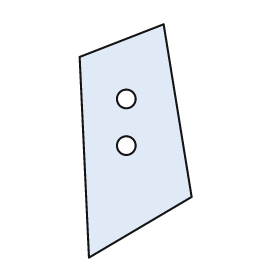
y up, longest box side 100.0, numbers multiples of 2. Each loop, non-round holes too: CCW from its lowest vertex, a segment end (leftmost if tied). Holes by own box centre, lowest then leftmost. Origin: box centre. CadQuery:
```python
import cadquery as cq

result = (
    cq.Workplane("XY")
    .moveTo(-20.0, -50.0)
    .lineTo(24.0, -24.0)
    .lineTo(12.0, 50.0)
    .lineTo(-24.0, 36.0)
    .close()
    .moveTo(-4.0, -2.0)
    .circle(4.0)
    .moveTo(-4.0, 18.0)
    .circle(4.0)
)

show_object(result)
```